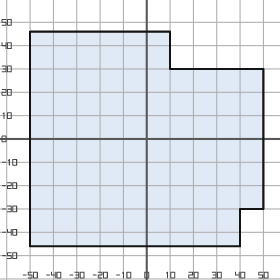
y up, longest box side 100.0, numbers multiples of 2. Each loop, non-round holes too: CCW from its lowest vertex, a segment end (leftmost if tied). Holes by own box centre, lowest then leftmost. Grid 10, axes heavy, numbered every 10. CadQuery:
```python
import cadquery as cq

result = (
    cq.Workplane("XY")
    .moveTo(-50.0, -46.0)
    .lineTo(40.0, -46.0)
    .lineTo(40.0, -30.0)
    .lineTo(50.0, -30.0)
    .lineTo(50.0, 30.0)
    .lineTo(10.0, 30.0)
    .lineTo(10.0, 46.0)
    .lineTo(-50.0, 46.0)
    .close()
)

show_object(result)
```